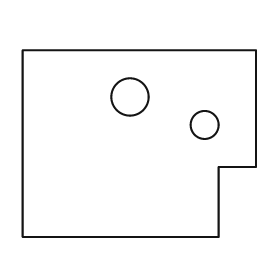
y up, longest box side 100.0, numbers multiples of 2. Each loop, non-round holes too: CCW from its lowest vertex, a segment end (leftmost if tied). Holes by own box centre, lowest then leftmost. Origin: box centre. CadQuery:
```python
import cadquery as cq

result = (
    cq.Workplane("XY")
    .moveTo(-50.0, -40.0)
    .lineTo(34.0, -40.0)
    .lineTo(34.0, -10.0)
    .lineTo(50.0, -10.0)
    .lineTo(50.0, 40.0)
    .lineTo(-50.0, 40.0)
    .close()
    .moveTo(28.0, 8.0)
    .circle(6.0)
    .moveTo(-4.0, 20.0)
    .circle(8.0)
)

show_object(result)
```